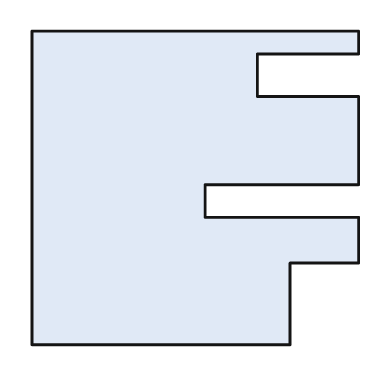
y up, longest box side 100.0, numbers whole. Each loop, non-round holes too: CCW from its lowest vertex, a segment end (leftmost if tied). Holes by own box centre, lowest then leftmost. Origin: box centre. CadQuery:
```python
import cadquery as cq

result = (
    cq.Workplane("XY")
    .moveTo(-50.0, -48.0)
    .lineTo(29.0, -48.0)
    .lineTo(29.0, -23.0)
    .lineTo(50.0, -23.0)
    .lineTo(50.0, -9.0)
    .lineTo(3.0, -9.0)
    .lineTo(3.0, 1.0)
    .lineTo(50.0, 1.0)
    .lineTo(50.0, 28.0)
    .lineTo(19.0, 28.0)
    .lineTo(19.0, 41.0)
    .lineTo(50.0, 41.0)
    .lineTo(50.0, 48.0)
    .lineTo(-50.0, 48.0)
    .close()
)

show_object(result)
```